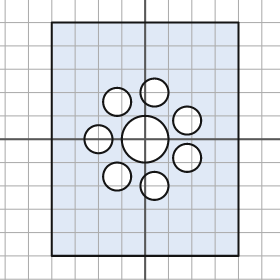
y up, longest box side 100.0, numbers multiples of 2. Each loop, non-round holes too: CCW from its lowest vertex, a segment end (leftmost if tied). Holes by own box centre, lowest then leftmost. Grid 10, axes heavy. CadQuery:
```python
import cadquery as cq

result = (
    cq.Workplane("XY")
    .moveTo(-40.0, -50.0)
    .lineTo(40.0, -50.0)
    .lineTo(40.0, 50.0)
    .lineTo(-40.0, 50.0)
    .close()
    .moveTo(4.0, -20.0)
    .circle(6.0)
    .moveTo(-12.0, -16.0)
    .circle(6.0)
    .moveTo(18.0, -8.0)
    .circle(6.0)
    .moveTo(-20.0, 0.0)
    .circle(6.0)
    .moveTo(0.0, 0.0)
    .circle(10.0)
    .moveTo(18.0, 8.0)
    .circle(6.0)
    .moveTo(-12.0, 16.0)
    .circle(6.0)
    .moveTo(4.0, 20.0)
    .circle(6.0)
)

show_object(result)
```